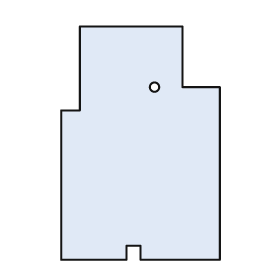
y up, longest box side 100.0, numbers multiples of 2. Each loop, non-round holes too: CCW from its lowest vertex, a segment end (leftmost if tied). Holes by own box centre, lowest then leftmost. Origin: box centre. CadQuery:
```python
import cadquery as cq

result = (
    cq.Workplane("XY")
    .moveTo(-34.0, -50.0)
    .lineTo(-6.0, -50.0)
    .lineTo(-6.0, -44.0)
    .lineTo(0.0, -44.0)
    .lineTo(0.0, -50.0)
    .lineTo(34.0, -50.0)
    .lineTo(34.0, 24.0)
    .lineTo(18.0, 24.0)
    .lineTo(18.0, 50.0)
    .lineTo(-26.0, 50.0)
    .lineTo(-26.0, 14.0)
    .lineTo(-34.0, 14.0)
    .close()
    .moveTo(6.0, 24.0)
    .circle(2.0)
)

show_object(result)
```